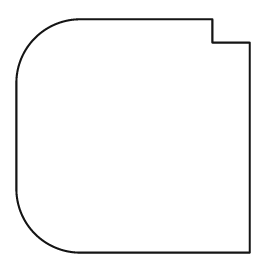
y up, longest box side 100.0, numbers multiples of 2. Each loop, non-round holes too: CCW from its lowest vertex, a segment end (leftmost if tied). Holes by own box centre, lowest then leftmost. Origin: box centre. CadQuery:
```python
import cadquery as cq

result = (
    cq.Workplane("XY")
    .moveTo(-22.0, -50.0)
    .lineTo(50.0, -50.0)
    .lineTo(50.0, 40.0)
    .lineTo(34.0, 40.0)
    .lineTo(34.0, 50.0)
    .lineTo(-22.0, 50.0)
    .threePointArc((-42.0, 42.0), (-50.0, 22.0))
    .lineTo(-50.0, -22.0)
    .threePointArc((-42.0, -42.0), (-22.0, -50.0))
    .close()
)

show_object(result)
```